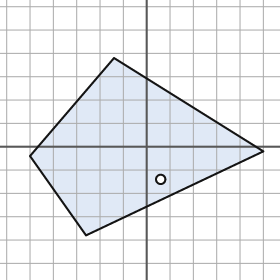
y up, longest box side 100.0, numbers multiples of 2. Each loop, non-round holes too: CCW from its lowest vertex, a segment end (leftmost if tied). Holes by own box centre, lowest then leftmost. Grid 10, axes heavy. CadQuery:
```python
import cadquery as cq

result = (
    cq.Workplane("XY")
    .moveTo(-26.0, -38.0)
    .lineTo(50.0, -2.0)
    .lineTo(-14.0, 38.0)
    .lineTo(-50.0, -4.0)
    .close()
    .moveTo(6.0, -14.0)
    .circle(2.0)
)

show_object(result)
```